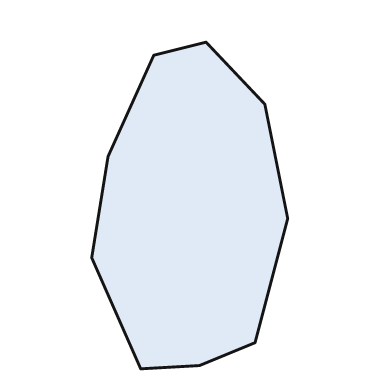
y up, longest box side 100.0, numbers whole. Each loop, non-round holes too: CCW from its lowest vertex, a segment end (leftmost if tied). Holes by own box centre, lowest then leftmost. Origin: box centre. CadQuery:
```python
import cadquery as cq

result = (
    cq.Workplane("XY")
    .moveTo(-15.0, -50.0)
    .lineTo(3.0, -49.0)
    .lineTo(20.0, -42.0)
    .lineTo(30.0, -4.0)
    .lineTo(23.0, 31.0)
    .lineTo(5.0, 50.0)
    .lineTo(-11.0, 46.0)
    .lineTo(-25.0, 15.0)
    .lineTo(-30.0, -16.0)
    .close()
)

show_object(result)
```